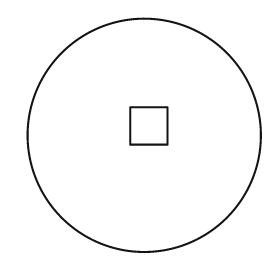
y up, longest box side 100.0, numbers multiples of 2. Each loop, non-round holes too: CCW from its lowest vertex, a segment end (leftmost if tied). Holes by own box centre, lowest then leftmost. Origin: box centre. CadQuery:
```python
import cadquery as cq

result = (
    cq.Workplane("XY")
    .moveTo(0.0, 0.0)
    .circle(50.0)
    .moveTo(-6.0, -4.0)
    .lineTo(10.0, -4.0)
    .lineTo(10.0, 12.0)
    .lineTo(-6.0, 12.0)
    .close()
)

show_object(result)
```